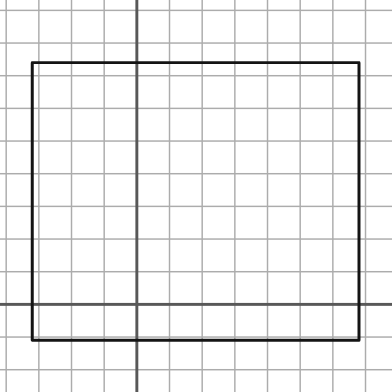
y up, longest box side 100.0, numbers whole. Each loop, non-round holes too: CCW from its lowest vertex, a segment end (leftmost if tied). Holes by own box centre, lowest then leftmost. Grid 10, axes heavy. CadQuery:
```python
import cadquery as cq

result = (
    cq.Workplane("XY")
    .moveTo(-32.0, -11.0)
    .lineTo(68.0, -11.0)
    .lineTo(68.0, 74.0)
    .lineTo(-32.0, 74.0)
    .close()
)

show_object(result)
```